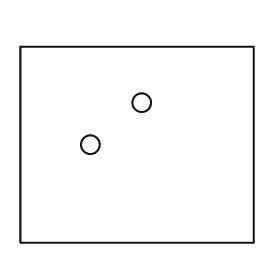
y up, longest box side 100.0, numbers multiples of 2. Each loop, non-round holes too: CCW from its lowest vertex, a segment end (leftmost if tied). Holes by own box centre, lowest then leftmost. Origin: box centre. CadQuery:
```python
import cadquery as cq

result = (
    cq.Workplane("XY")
    .moveTo(-50.0, -42.0)
    .lineTo(50.0, -42.0)
    .lineTo(50.0, 42.0)
    .lineTo(-50.0, 42.0)
    .close()
    .moveTo(-20.0, 0.0)
    .circle(4.0)
    .moveTo(2.0, 18.0)
    .circle(4.0)
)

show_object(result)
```